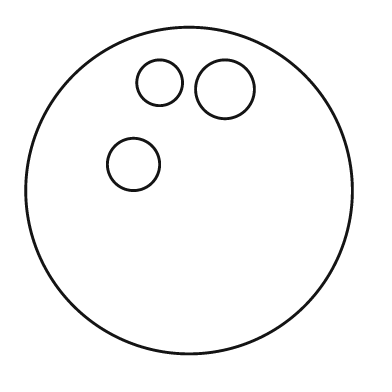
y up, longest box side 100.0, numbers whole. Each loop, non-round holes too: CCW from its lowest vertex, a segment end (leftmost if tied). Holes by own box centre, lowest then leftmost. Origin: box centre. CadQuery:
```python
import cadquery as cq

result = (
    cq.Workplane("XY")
    .moveTo(0.0, 0.0)
    .circle(50.0)
    .moveTo(-17.0, 8.0)
    .circle(8.0)
    .moveTo(11.0, 31.0)
    .circle(9.0)
    .moveTo(-9.0, 33.0)
    .circle(7.0)
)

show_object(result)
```